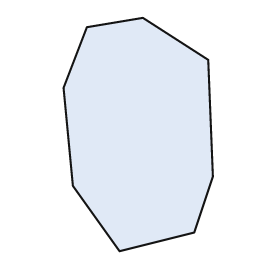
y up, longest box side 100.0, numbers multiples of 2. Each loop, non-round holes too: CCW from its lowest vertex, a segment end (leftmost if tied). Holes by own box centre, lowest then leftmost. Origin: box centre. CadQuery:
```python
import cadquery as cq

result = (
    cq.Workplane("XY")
    .moveTo(-8.0, -50.0)
    .lineTo(24.0, -42.0)
    .lineTo(32.0, -18.0)
    .lineTo(30.0, 32.0)
    .lineTo(2.0, 50.0)
    .lineTo(-22.0, 46.0)
    .lineTo(-32.0, 20.0)
    .lineTo(-28.0, -22.0)
    .close()
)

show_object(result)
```